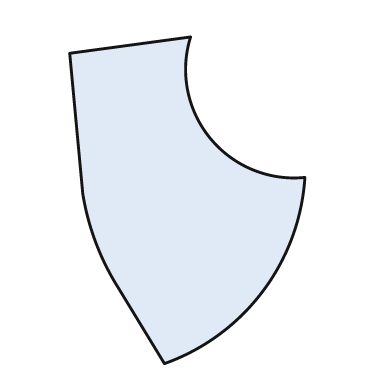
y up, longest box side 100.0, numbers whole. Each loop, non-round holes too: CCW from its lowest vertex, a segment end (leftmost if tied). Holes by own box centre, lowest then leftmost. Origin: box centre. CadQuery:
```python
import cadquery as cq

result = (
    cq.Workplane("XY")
    .moveTo(-7.0, -50.0)
    .threePointArc((23.0, -28.0), (36.0, 7.0))
    .threePointArc((7.0, 19.0), (1.0, 50.0))
    .lineTo(-36.0, 45.0)
    .lineTo(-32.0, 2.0)
    .threePointArc((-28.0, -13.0), (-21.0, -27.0))
    .close()
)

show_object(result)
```